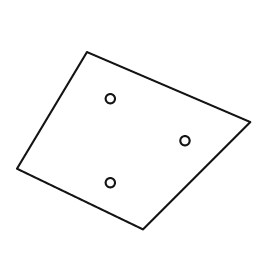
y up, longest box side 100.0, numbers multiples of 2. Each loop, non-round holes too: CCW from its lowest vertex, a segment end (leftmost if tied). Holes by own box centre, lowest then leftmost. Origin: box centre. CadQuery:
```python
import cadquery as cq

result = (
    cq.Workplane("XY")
    .moveTo(4.0, -38.0)
    .lineTo(50.0, 8.0)
    .lineTo(-20.0, 38.0)
    .lineTo(-50.0, -12.0)
    .close()
    .moveTo(-10.0, -18.0)
    .circle(2.0)
    .moveTo(22.0, 0.0)
    .circle(2.0)
    .moveTo(-10.0, 18.0)
    .circle(2.0)
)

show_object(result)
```